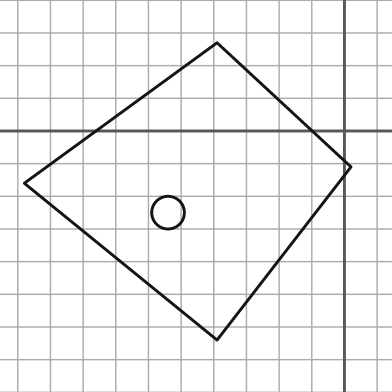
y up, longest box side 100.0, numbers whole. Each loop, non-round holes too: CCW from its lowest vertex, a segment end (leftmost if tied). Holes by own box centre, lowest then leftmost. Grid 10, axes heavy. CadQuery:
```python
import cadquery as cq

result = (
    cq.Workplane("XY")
    .moveTo(-39.0, -64.0)
    .lineTo(2.0, -11.0)
    .lineTo(-39.0, 27.0)
    .lineTo(-98.0, -16.0)
    .close()
    .moveTo(-54.0, -25.0)
    .circle(5.0)
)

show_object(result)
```